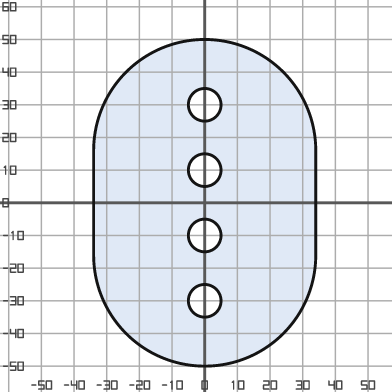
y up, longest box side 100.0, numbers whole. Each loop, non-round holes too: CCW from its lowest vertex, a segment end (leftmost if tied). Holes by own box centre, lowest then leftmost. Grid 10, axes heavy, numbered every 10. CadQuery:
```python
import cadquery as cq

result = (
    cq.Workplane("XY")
    .moveTo(-34.0, -16.0)
    .threePointArc((0.0, -50.0), (34.0, -16.0))
    .lineTo(34.0, 16.0)
    .threePointArc((0.0, 50.0), (-34.0, 16.0))
    .close()
    .moveTo(0.0, -30.0)
    .circle(5.0)
    .moveTo(0.0, -10.0)
    .circle(5.0)
    .moveTo(0.0, 10.0)
    .circle(5.0)
    .moveTo(0.0, 30.0)
    .circle(5.0)
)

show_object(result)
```